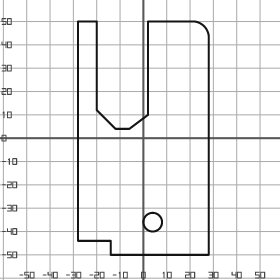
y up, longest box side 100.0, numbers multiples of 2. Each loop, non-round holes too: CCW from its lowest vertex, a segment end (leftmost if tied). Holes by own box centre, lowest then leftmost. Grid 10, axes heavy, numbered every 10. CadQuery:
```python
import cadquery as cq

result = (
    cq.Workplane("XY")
    .moveTo(-14.0, -50.0)
    .lineTo(28.0, -50.0)
    .lineTo(28.0, 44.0)
    .threePointArc((26.0, 48.0), (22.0, 50.0))
    .lineTo(2.0, 50.0)
    .lineTo(2.0, 10.0)
    .lineTo(-6.0, 4.0)
    .lineTo(-12.0, 4.0)
    .lineTo(-20.0, 12.0)
    .lineTo(-20.0, 50.0)
    .lineTo(-28.0, 50.0)
    .lineTo(-28.0, -44.0)
    .lineTo(-14.0, -44.0)
    .close()
    .moveTo(4.0, -36.0)
    .circle(4.0)
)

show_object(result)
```